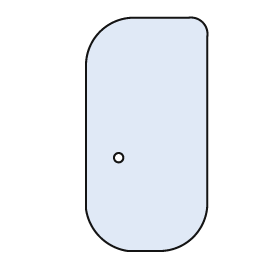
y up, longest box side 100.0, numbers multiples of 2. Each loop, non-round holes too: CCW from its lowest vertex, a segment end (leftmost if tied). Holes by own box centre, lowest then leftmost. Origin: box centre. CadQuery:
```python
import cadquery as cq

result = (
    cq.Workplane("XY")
    .moveTo(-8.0, -50.0)
    .lineTo(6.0, -50.0)
    .threePointArc((20.0, -44.0), (26.0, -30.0))
    .lineTo(26.0, 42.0)
    .threePointArc((24.0, 48.0), (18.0, 50.0))
    .lineTo(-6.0, 50.0)
    .threePointArc((-20.0, 44.0), (-26.0, 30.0))
    .lineTo(-26.0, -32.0)
    .threePointArc((-20.0, -44.0), (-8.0, -50.0))
    .close()
    .moveTo(-12.0, -10.0)
    .circle(2.0)
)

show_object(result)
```